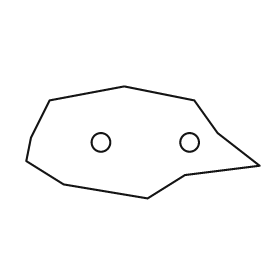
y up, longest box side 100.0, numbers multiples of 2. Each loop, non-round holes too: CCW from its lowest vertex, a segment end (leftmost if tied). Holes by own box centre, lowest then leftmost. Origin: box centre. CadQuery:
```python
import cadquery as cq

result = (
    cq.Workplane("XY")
    .moveTo(2.0, -24.0)
    .lineTo(18.0, -14.0)
    .lineTo(50.0, -10.0)
    .lineTo(32.0, 4.0)
    .lineTo(22.0, 18.0)
    .lineTo(-8.0, 24.0)
    .lineTo(-40.0, 18.0)
    .lineTo(-48.0, 2.0)
    .lineTo(-50.0, -8.0)
    .lineTo(-34.0, -18.0)
    .close()
    .moveTo(-18.0, 0.0)
    .circle(4.0)
    .moveTo(20.0, 0.0)
    .circle(4.0)
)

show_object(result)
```